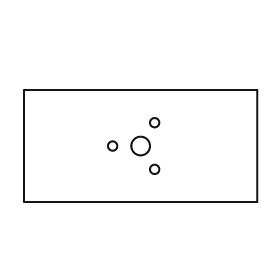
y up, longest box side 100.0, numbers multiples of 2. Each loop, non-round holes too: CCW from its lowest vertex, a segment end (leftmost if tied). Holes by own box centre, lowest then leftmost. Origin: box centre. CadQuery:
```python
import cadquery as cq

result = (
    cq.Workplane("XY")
    .moveTo(-50.0, -24.0)
    .lineTo(50.0, -24.0)
    .lineTo(50.0, 24.0)
    .lineTo(-50.0, 24.0)
    .close()
    .moveTo(6.0, -10.0)
    .circle(2.0)
    .moveTo(-12.0, 0.0)
    .circle(2.0)
    .moveTo(0.0, 0.0)
    .circle(4.0)
    .moveTo(6.0, 10.0)
    .circle(2.0)
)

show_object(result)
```